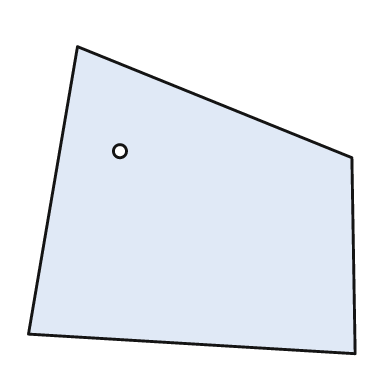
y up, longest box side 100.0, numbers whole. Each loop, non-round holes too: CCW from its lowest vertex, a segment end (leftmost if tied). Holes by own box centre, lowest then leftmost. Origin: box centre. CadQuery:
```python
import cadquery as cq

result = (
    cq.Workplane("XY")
    .moveTo(50.0, -47.0)
    .lineTo(49.0, 13.0)
    .lineTo(-35.0, 47.0)
    .lineTo(-50.0, -41.0)
    .close()
    .moveTo(-22.0, 15.0)
    .circle(2.0)
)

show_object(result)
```